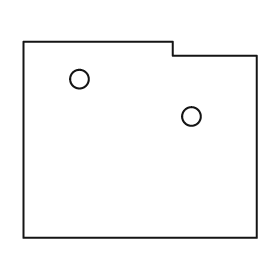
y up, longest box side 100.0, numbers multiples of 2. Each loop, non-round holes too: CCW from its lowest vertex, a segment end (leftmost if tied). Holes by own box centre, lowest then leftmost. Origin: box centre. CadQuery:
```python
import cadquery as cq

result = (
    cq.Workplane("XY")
    .moveTo(-50.0, -42.0)
    .lineTo(50.0, -42.0)
    .lineTo(50.0, 36.0)
    .lineTo(14.0, 36.0)
    .lineTo(14.0, 42.0)
    .lineTo(-50.0, 42.0)
    .close()
    .moveTo(22.0, 10.0)
    .circle(4.0)
    .moveTo(-26.0, 26.0)
    .circle(4.0)
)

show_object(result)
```